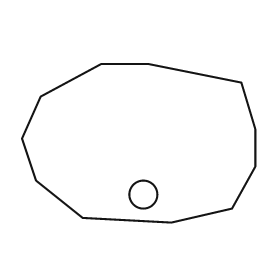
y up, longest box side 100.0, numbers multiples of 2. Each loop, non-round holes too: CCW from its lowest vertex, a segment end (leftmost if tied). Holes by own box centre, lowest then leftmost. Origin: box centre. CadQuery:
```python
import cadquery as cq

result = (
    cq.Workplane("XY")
    .moveTo(14.0, -34.0)
    .lineTo(40.0, -28.0)
    .lineTo(50.0, -10.0)
    .lineTo(50.0, 6.0)
    .lineTo(44.0, 26.0)
    .lineTo(4.0, 34.0)
    .lineTo(-16.0, 34.0)
    .lineTo(-42.0, 20.0)
    .lineTo(-50.0, 2.0)
    .lineTo(-44.0, -16.0)
    .lineTo(-24.0, -32.0)
    .close()
    .moveTo(2.0, -22.0)
    .circle(6.0)
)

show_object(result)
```